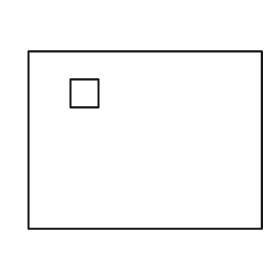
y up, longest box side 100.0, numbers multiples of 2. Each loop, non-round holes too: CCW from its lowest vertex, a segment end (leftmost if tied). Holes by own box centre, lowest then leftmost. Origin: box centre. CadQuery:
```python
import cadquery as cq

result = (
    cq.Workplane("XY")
    .moveTo(-50.0, -38.0)
    .lineTo(50.0, -38.0)
    .lineTo(50.0, 38.0)
    .lineTo(-50.0, 38.0)
    .close()
    .moveTo(-32.0, 14.0)
    .lineTo(-20.0, 14.0)
    .lineTo(-20.0, 26.0)
    .lineTo(-32.0, 26.0)
    .close()
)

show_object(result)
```